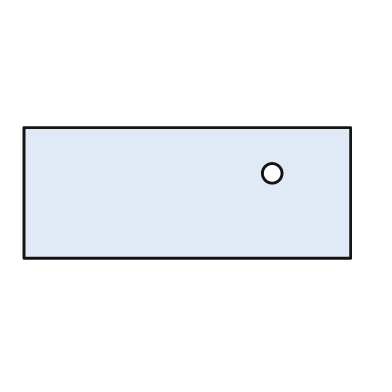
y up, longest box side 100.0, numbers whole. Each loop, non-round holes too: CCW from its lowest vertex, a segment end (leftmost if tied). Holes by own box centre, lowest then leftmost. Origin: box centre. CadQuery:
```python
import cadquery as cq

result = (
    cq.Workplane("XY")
    .moveTo(-50.0, -20.0)
    .lineTo(50.0, -20.0)
    .lineTo(50.0, 20.0)
    .lineTo(-50.0, 20.0)
    .close()
    .moveTo(26.0, 6.0)
    .circle(3.0)
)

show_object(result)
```